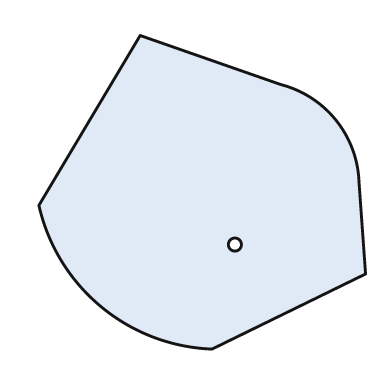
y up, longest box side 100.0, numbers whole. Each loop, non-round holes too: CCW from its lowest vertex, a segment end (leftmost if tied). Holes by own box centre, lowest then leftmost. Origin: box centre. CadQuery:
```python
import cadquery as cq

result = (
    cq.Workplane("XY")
    .moveTo(3.0, -48.0)
    .lineTo(50.0, -25.0)
    .lineTo(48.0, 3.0)
    .threePointArc((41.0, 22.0), (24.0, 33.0))
    .lineTo(-19.0, 48.0)
    .lineTo(-50.0, -4.0)
    .threePointArc((-31.0, -35.0), (3.0, -48.0))
    .close()
    .moveTo(10.0, -16.0)
    .circle(2.0)
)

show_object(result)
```